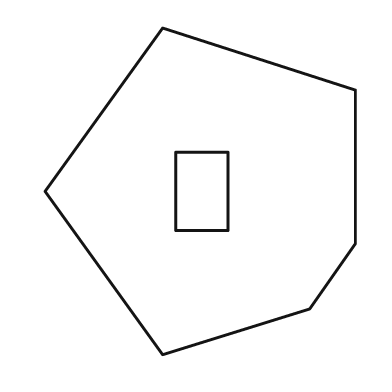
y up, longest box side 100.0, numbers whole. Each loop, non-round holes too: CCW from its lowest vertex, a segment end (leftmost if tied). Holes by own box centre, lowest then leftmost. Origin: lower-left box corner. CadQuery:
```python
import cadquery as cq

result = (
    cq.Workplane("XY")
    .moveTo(36.0, 0.0)
    .lineTo(81.0, 14.0)
    .lineTo(95.0, 34.0)
    .lineTo(95.0, 81.0)
    .lineTo(36.0, 100.0)
    .lineTo(0.0, 50.0)
    .close()
    .moveTo(40.0, 38.0)
    .lineTo(56.0, 38.0)
    .lineTo(56.0, 62.0)
    .lineTo(40.0, 62.0)
    .close()
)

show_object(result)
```